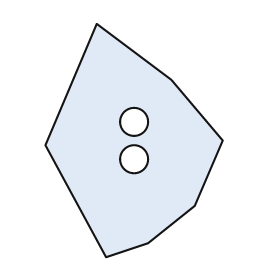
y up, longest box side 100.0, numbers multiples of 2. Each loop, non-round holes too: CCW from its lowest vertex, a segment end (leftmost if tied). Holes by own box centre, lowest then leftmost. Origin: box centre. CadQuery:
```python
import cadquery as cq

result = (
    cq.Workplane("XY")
    .moveTo(-12.0, -50.0)
    .lineTo(6.0, -44.0)
    .lineTo(26.0, -28.0)
    .lineTo(38.0, 0.0)
    .lineTo(16.0, 26.0)
    .lineTo(-16.0, 50.0)
    .lineTo(-38.0, -2.0)
    .close()
    .moveTo(0.0, -8.0)
    .circle(6.0)
    .moveTo(0.0, 8.0)
    .circle(6.0)
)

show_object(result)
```